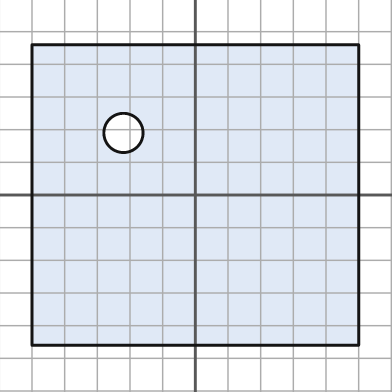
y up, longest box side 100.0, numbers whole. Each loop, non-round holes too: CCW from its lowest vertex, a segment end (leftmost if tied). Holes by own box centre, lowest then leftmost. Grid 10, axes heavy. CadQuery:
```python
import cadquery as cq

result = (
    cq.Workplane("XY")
    .moveTo(-50.0, -46.0)
    .lineTo(50.0, -46.0)
    .lineTo(50.0, 46.0)
    .lineTo(-50.0, 46.0)
    .close()
    .moveTo(-22.0, 19.0)
    .circle(6.0)
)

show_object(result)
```